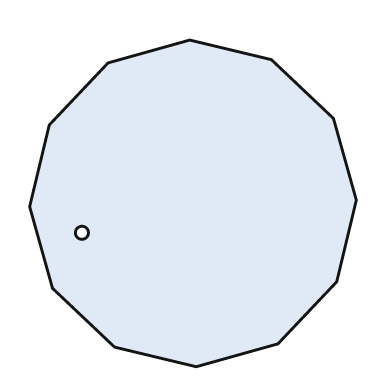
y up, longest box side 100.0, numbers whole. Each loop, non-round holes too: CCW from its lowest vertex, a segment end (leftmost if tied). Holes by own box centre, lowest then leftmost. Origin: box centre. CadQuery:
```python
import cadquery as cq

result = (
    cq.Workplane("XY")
    .moveTo(1.0, -50.0)
    .lineTo(26.0, -43.0)
    .lineTo(44.0, -24.0)
    .lineTo(50.0, 1.0)
    .lineTo(43.0, 26.0)
    .lineTo(24.0, 44.0)
    .lineTo(-1.0, 50.0)
    .lineTo(-26.0, 43.0)
    .lineTo(-44.0, 24.0)
    .lineTo(-50.0, -1.0)
    .lineTo(-43.0, -26.0)
    .lineTo(-24.0, -44.0)
    .close()
    .moveTo(-34.0, -9.0)
    .circle(2.0)
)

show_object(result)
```